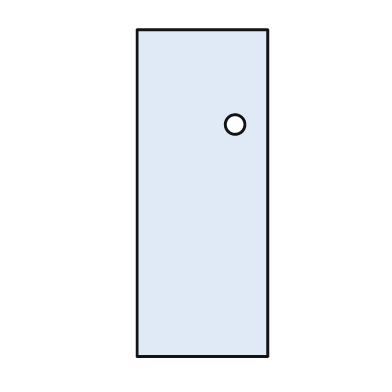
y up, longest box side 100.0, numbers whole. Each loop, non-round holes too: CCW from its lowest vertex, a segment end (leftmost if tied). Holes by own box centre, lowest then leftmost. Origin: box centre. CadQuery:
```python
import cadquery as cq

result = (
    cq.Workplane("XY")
    .moveTo(-20.0, -50.0)
    .lineTo(20.0, -50.0)
    .lineTo(20.0, 50.0)
    .lineTo(-20.0, 50.0)
    .close()
    .moveTo(10.0, 21.0)
    .circle(3.0)
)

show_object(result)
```